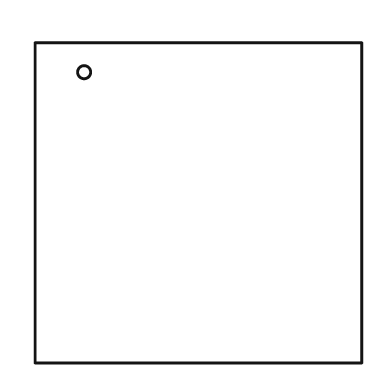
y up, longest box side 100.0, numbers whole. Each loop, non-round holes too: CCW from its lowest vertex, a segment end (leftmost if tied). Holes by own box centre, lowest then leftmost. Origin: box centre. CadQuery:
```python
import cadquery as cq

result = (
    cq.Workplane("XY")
    .moveTo(-50.0, -49.0)
    .lineTo(50.0, -49.0)
    .lineTo(50.0, 49.0)
    .lineTo(-50.0, 49.0)
    .close()
    .moveTo(-35.0, 40.0)
    .circle(2.0)
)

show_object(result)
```